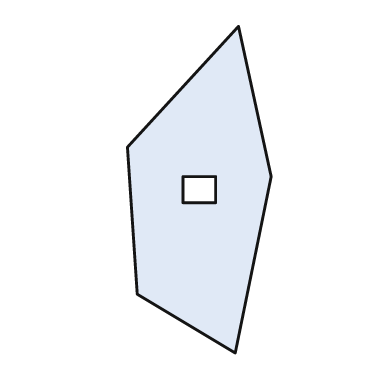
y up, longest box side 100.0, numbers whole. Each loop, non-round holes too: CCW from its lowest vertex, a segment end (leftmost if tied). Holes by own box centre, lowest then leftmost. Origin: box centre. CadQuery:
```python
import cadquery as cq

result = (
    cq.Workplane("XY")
    .moveTo(11.0, -50.0)
    .lineTo(22.0, 4.0)
    .lineTo(12.0, 50.0)
    .lineTo(-22.0, 13.0)
    .lineTo(-19.0, -32.0)
    .close()
    .moveTo(-5.0, -4.0)
    .lineTo(5.0, -4.0)
    .lineTo(5.0, 4.0)
    .lineTo(-5.0, 4.0)
    .close()
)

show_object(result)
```